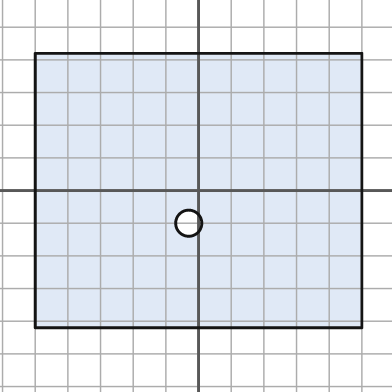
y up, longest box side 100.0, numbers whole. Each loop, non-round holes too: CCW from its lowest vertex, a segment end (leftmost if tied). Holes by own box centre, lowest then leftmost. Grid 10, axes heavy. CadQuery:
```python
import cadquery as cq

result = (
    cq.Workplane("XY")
    .moveTo(-50.0, -42.0)
    .lineTo(50.0, -42.0)
    .lineTo(50.0, 42.0)
    .lineTo(-50.0, 42.0)
    .close()
    .moveTo(-3.0, -10.0)
    .circle(4.0)
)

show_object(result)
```